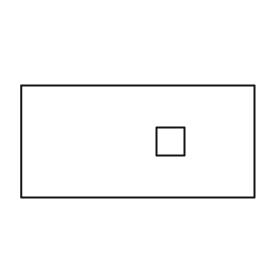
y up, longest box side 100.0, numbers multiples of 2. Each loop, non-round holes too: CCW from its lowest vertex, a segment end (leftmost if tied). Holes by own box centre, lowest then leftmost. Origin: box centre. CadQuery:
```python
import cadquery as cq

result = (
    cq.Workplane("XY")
    .moveTo(-50.0, -24.0)
    .lineTo(50.0, -24.0)
    .lineTo(50.0, 24.0)
    .lineTo(-50.0, 24.0)
    .close()
    .moveTo(8.0, -6.0)
    .lineTo(20.0, -6.0)
    .lineTo(20.0, 6.0)
    .lineTo(8.0, 6.0)
    .close()
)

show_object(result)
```